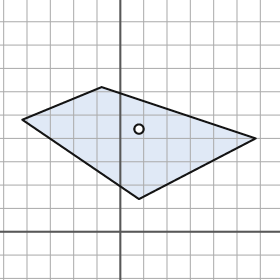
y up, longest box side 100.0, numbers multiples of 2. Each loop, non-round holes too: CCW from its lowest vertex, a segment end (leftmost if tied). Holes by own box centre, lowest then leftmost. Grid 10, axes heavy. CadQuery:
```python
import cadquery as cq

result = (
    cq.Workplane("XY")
    .moveTo(8.0, 14.0)
    .lineTo(58.0, 40.0)
    .lineTo(-8.0, 62.0)
    .lineTo(-42.0, 48.0)
    .close()
    .moveTo(8.0, 44.0)
    .circle(2.0)
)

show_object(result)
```